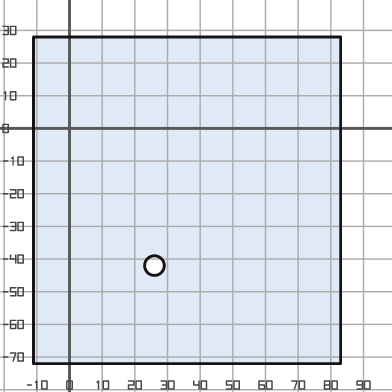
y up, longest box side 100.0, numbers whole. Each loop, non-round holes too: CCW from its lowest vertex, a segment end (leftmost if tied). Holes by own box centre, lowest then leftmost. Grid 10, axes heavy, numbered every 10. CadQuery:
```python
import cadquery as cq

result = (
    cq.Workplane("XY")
    .moveTo(-11.0, -72.0)
    .lineTo(83.0, -72.0)
    .lineTo(83.0, 28.0)
    .lineTo(-11.0, 28.0)
    .close()
    .moveTo(26.0, -42.0)
    .circle(3.0)
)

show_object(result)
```